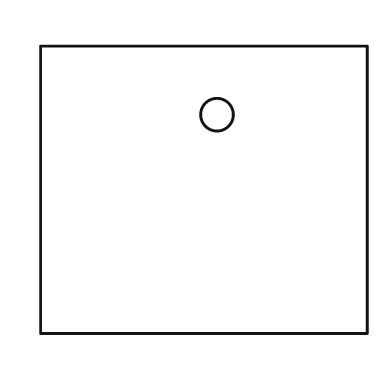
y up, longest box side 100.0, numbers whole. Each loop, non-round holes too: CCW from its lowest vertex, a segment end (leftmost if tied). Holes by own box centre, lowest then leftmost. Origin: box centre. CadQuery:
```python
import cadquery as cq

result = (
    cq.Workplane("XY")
    .moveTo(-50.0, -44.0)
    .lineTo(50.0, -44.0)
    .lineTo(50.0, 44.0)
    .lineTo(-50.0, 44.0)
    .close()
    .moveTo(4.0, 23.0)
    .circle(5.0)
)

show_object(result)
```